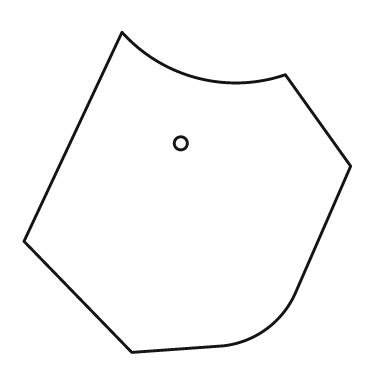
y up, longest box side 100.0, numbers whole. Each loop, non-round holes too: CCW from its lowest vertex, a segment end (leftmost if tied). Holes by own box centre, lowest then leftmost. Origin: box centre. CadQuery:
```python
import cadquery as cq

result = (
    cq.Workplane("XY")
    .moveTo(-17.0, -49.0)
    .lineTo(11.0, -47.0)
    .threePointArc((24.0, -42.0), (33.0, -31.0))
    .lineTo(50.0, 8.0)
    .lineTo(30.0, 36.0)
    .threePointArc((3.0, 35.0), (-20.0, 49.0))
    .lineTo(-50.0, -15.0)
    .close()
    .moveTo(-2.0, 15.0)
    .circle(2.0)
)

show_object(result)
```